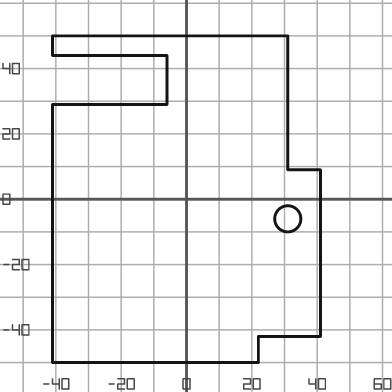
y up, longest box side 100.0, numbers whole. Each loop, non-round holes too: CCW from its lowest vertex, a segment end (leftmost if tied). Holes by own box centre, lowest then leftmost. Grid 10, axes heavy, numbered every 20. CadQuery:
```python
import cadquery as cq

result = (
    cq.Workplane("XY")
    .moveTo(-41.0, -50.0)
    .lineTo(22.0, -50.0)
    .lineTo(22.0, -42.0)
    .lineTo(41.0, -42.0)
    .lineTo(41.0, 9.0)
    .lineTo(31.0, 9.0)
    .lineTo(31.0, 50.0)
    .lineTo(-41.0, 50.0)
    .lineTo(-41.0, 44.0)
    .lineTo(-6.0, 44.0)
    .lineTo(-6.0, 29.0)
    .lineTo(-41.0, 29.0)
    .close()
    .moveTo(31.0, -6.0)
    .circle(4.0)
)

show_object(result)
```